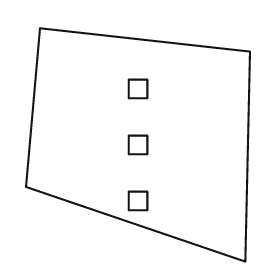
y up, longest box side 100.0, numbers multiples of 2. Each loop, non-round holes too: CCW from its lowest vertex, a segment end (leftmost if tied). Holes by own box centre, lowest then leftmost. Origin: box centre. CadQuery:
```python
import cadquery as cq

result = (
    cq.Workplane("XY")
    .moveTo(46.0, -50.0)
    .lineTo(48.0, 40.0)
    .lineTo(-42.0, 50.0)
    .lineTo(-48.0, -18.0)
    .close()
    .moveTo(-4.0, -28.0)
    .lineTo(4.0, -28.0)
    .lineTo(4.0, -20.0)
    .lineTo(-4.0, -20.0)
    .close()
    .moveTo(-4.0, -4.0)
    .lineTo(4.0, -4.0)
    .lineTo(4.0, 4.0)
    .lineTo(-4.0, 4.0)
    .close()
    .moveTo(-4.0, 20.0)
    .lineTo(4.0, 20.0)
    .lineTo(4.0, 28.0)
    .lineTo(-4.0, 28.0)
    .close()
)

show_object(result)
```